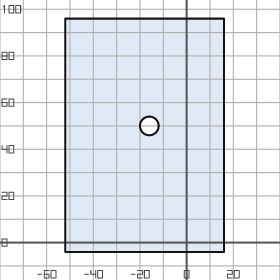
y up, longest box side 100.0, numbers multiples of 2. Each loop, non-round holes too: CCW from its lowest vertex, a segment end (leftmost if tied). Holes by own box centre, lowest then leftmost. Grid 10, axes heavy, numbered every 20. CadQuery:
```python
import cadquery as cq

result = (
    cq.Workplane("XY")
    .moveTo(-52.0, -4.0)
    .lineTo(16.0, -4.0)
    .lineTo(16.0, 96.0)
    .lineTo(-52.0, 96.0)
    .close()
    .moveTo(-16.0, 50.0)
    .circle(4.0)
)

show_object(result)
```